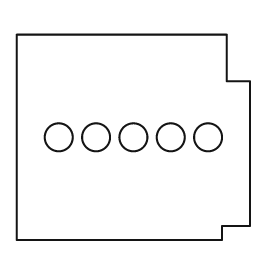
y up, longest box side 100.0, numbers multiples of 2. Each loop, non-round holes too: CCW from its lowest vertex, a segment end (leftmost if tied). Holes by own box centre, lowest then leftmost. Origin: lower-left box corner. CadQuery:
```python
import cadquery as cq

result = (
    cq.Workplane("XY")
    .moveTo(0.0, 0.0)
    .lineTo(88.0, 0.0)
    .lineTo(88.0, 6.0)
    .lineTo(100.0, 6.0)
    .lineTo(100.0, 68.0)
    .lineTo(90.0, 68.0)
    .lineTo(90.0, 88.0)
    .lineTo(0.0, 88.0)
    .close()
    .moveTo(18.0, 44.0)
    .circle(6.0)
    .moveTo(34.0, 44.0)
    .circle(6.0)
    .moveTo(50.0, 44.0)
    .circle(6.0)
    .moveTo(66.0, 44.0)
    .circle(6.0)
    .moveTo(82.0, 44.0)
    .circle(6.0)
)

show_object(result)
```